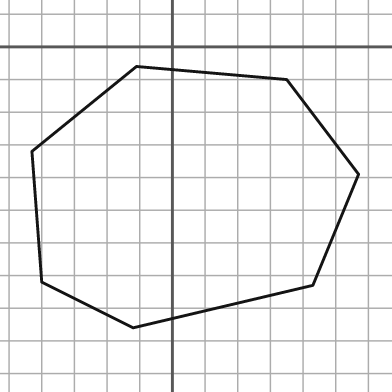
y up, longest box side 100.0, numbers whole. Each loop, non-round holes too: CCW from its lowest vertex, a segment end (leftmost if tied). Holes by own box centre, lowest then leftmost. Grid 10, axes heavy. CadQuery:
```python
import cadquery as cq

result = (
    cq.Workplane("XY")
    .moveTo(-12.0, -86.0)
    .lineTo(43.0, -73.0)
    .lineTo(57.0, -39.0)
    .lineTo(35.0, -10.0)
    .lineTo(-11.0, -6.0)
    .lineTo(-43.0, -32.0)
    .lineTo(-40.0, -72.0)
    .close()
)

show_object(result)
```